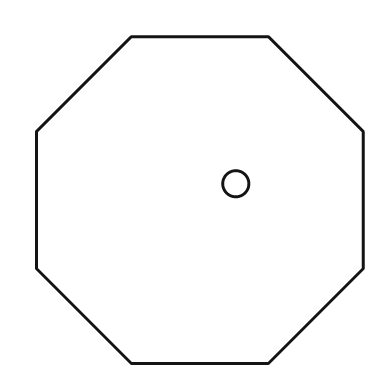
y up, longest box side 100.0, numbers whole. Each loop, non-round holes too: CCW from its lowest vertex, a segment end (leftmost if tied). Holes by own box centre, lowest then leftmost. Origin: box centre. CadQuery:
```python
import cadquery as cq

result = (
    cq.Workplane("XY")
    .moveTo(-21.0, -50.0)
    .lineTo(21.0, -50.0)
    .lineTo(50.0, -21.0)
    .lineTo(50.0, 21.0)
    .lineTo(21.0, 50.0)
    .lineTo(-21.0, 50.0)
    .lineTo(-50.0, 21.0)
    .lineTo(-50.0, -21.0)
    .close()
    .moveTo(11.0, 5.0)
    .circle(4.0)
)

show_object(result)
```